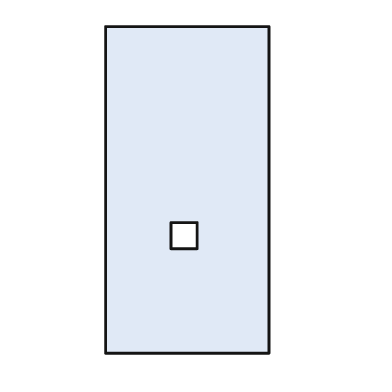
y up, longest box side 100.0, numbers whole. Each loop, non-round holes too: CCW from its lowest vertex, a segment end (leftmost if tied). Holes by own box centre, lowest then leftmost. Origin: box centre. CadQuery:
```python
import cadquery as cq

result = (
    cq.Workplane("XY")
    .moveTo(-25.0, -50.0)
    .lineTo(25.0, -50.0)
    .lineTo(25.0, 50.0)
    .lineTo(-25.0, 50.0)
    .close()
    .moveTo(-5.0, -18.0)
    .lineTo(3.0, -18.0)
    .lineTo(3.0, -10.0)
    .lineTo(-5.0, -10.0)
    .close()
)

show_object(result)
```